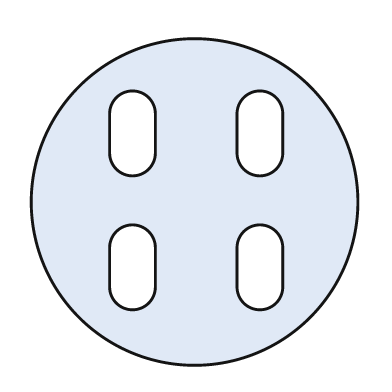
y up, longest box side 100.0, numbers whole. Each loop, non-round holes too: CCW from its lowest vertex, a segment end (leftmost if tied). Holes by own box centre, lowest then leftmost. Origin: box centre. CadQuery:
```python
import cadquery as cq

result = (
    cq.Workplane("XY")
    .moveTo(0.0, 0.0)
    .circle(50.0)
    .moveTo(-26.0, -26.0)
    .threePointArc((-19.0, -33.0), (-12.0, -26.0))
    .lineTo(-12.0, -14.0)
    .threePointArc((-19.0, -7.0), (-26.0, -14.0))
    .close()
    .moveTo(13.0, -26.0)
    .threePointArc((20.0, -33.0), (27.0, -26.0))
    .lineTo(27.0, -14.0)
    .threePointArc((20.0, -7.0), (13.0, -14.0))
    .close()
    .moveTo(-26.0, 15.0)
    .threePointArc((-19.0, 8.0), (-12.0, 15.0))
    .lineTo(-12.0, 27.0)
    .threePointArc((-19.0, 34.0), (-26.0, 27.0))
    .close()
    .moveTo(13.0, 15.0)
    .threePointArc((20.0, 8.0), (27.0, 15.0))
    .lineTo(27.0, 27.0)
    .threePointArc((20.0, 34.0), (13.0, 27.0))
    .close()
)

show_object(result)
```